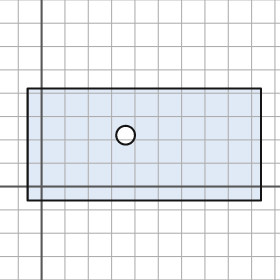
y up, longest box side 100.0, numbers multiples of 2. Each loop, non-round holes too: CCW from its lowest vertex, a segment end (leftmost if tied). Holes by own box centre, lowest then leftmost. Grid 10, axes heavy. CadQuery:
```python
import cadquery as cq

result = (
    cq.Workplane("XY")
    .moveTo(-6.0, -6.0)
    .lineTo(94.0, -6.0)
    .lineTo(94.0, 42.0)
    .lineTo(-6.0, 42.0)
    .close()
    .moveTo(36.0, 22.0)
    .circle(4.0)
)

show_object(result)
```